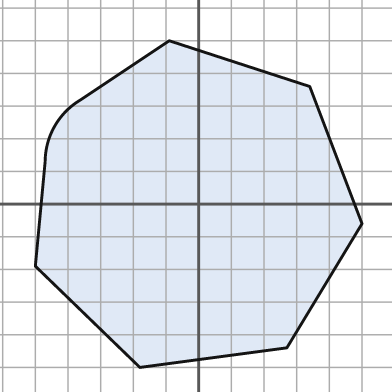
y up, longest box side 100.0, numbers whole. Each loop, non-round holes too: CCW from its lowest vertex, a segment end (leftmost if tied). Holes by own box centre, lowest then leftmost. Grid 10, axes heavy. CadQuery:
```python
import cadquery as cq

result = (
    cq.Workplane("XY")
    .moveTo(-18.0, -50.0)
    .lineTo(27.0, -44.0)
    .lineTo(50.0, -6.0)
    .lineTo(34.0, 36.0)
    .lineTo(-9.0, 50.0)
    .lineTo(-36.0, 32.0)
    .threePointArc((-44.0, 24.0), (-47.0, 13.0))
    .lineTo(-50.0, -19.0)
    .close()
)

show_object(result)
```